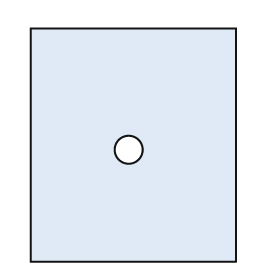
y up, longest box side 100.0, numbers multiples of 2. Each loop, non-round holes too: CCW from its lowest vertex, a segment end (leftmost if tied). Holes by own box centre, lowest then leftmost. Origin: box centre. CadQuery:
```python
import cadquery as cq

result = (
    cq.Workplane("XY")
    .moveTo(-44.0, -50.0)
    .lineTo(44.0, -50.0)
    .lineTo(44.0, 50.0)
    .lineTo(-44.0, 50.0)
    .close()
    .moveTo(-2.0, -2.0)
    .circle(6.0)
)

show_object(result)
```